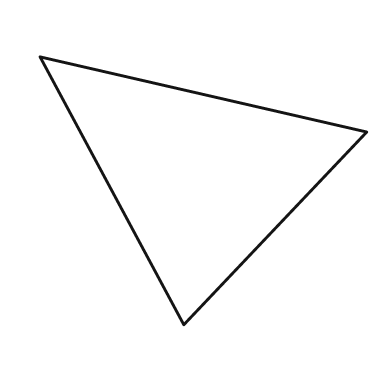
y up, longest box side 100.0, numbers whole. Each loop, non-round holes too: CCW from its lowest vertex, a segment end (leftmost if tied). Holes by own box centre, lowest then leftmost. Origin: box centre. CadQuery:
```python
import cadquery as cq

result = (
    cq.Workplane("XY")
    .moveTo(-6.0, -41.0)
    .lineTo(50.0, 18.0)
    .lineTo(-50.0, 41.0)
    .close()
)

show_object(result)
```